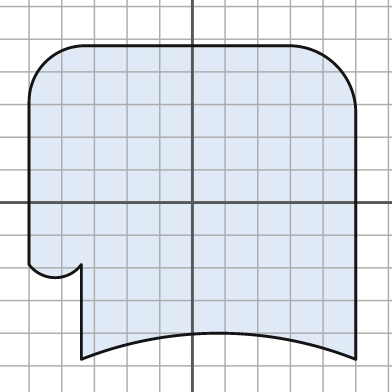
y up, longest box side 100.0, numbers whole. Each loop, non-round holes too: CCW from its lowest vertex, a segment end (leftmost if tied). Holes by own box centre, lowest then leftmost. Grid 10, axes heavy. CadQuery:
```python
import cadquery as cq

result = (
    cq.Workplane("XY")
    .moveTo(-34.0, -48.0)
    .threePointArc((8.0, -40.0), (50.0, -48.0))
    .lineTo(50.0, 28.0)
    .threePointArc((44.0, 42.0), (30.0, 48.0))
    .lineTo(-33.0, 48.0)
    .threePointArc((-45.0, 43.0), (-50.0, 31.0))
    .lineTo(-50.0, -19.0)
    .threePointArc((-42.0, -23.0), (-34.0, -19.0))
    .close()
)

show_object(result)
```